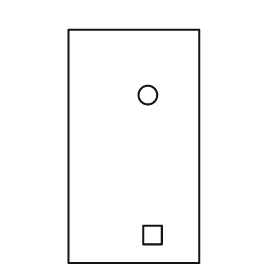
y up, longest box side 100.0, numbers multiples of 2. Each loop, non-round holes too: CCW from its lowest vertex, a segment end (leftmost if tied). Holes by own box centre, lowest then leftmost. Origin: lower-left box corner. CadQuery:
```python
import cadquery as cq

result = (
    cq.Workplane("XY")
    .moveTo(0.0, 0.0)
    .lineTo(56.0, 0.0)
    .lineTo(56.0, 100.0)
    .lineTo(0.0, 100.0)
    .close()
    .moveTo(32.0, 8.0)
    .lineTo(40.0, 8.0)
    .lineTo(40.0, 16.0)
    .lineTo(32.0, 16.0)
    .close()
    .moveTo(34.0, 72.0)
    .circle(4.0)
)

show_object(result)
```